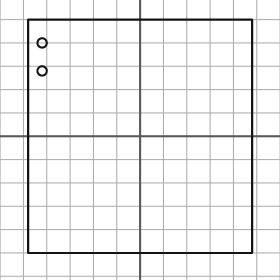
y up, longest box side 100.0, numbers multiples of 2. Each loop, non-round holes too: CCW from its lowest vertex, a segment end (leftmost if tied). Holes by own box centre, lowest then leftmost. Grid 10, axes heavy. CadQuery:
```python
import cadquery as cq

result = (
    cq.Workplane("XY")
    .moveTo(-48.0, -50.0)
    .lineTo(48.0, -50.0)
    .lineTo(48.0, 50.0)
    .lineTo(-48.0, 50.0)
    .close()
    .moveTo(-42.0, 28.0)
    .circle(2.0)
    .moveTo(-42.0, 40.0)
    .circle(2.0)
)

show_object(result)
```